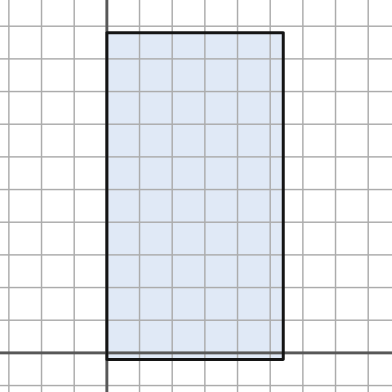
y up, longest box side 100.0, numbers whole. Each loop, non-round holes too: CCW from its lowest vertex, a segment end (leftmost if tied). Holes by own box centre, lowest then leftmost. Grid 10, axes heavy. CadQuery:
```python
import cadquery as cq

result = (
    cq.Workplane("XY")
    .moveTo(0.0, -2.0)
    .lineTo(54.0, -2.0)
    .lineTo(54.0, 98.0)
    .lineTo(0.0, 98.0)
    .close()
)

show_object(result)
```